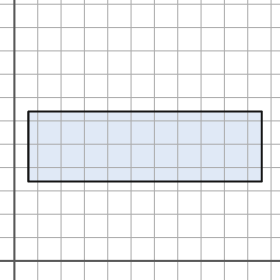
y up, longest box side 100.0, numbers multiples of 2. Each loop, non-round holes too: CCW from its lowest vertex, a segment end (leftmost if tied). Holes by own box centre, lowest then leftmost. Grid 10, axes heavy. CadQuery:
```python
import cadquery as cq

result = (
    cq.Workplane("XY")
    .moveTo(6.0, 34.0)
    .lineTo(106.0, 34.0)
    .lineTo(106.0, 64.0)
    .lineTo(6.0, 64.0)
    .close()
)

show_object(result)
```